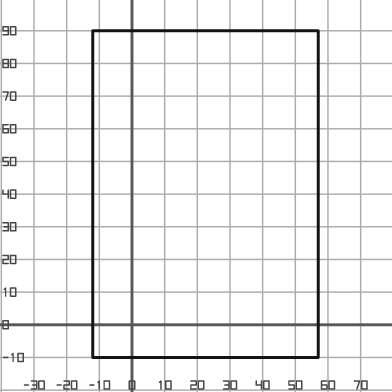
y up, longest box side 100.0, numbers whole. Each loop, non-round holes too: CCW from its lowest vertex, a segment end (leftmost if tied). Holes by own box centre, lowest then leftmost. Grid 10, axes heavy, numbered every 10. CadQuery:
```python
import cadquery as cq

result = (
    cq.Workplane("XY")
    .moveTo(-12.0, -10.0)
    .lineTo(57.0, -10.0)
    .lineTo(57.0, 90.0)
    .lineTo(-12.0, 90.0)
    .close()
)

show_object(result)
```